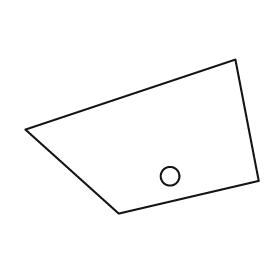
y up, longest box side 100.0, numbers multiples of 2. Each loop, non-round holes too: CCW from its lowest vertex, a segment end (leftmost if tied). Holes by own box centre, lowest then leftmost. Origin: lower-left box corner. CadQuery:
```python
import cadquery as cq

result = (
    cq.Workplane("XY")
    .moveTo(40.0, 0.0)
    .lineTo(100.0, 14.0)
    .lineTo(90.0, 66.0)
    .lineTo(0.0, 36.0)
    .close()
    .moveTo(62.0, 16.0)
    .circle(4.0)
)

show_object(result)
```